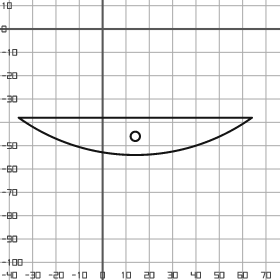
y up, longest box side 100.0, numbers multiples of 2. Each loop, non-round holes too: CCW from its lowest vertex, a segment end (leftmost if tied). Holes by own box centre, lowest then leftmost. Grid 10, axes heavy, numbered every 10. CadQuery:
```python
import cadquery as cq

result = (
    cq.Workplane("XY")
    .moveTo(-36.0, -38.0)
    .threePointArc((14.0, -54.0), (64.0, -38.0))
    .close()
    .moveTo(14.0, -46.0)
    .circle(2.0)
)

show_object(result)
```